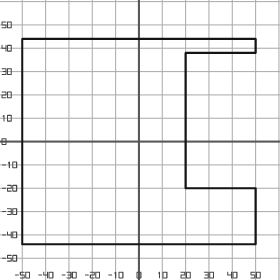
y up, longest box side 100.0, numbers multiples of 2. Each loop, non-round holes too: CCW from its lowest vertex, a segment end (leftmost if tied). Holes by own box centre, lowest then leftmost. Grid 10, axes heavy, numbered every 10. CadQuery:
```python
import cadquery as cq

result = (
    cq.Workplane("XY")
    .moveTo(-50.0, -44.0)
    .lineTo(50.0, -44.0)
    .lineTo(50.0, -20.0)
    .lineTo(20.0, -20.0)
    .lineTo(20.0, 38.0)
    .lineTo(50.0, 38.0)
    .lineTo(50.0, 44.0)
    .lineTo(-50.0, 44.0)
    .close()
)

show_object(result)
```